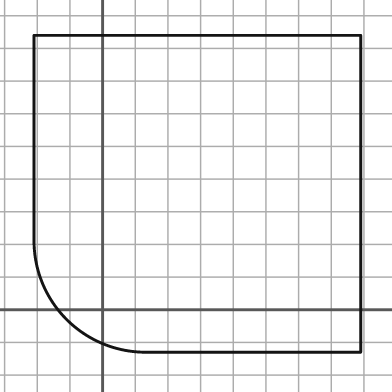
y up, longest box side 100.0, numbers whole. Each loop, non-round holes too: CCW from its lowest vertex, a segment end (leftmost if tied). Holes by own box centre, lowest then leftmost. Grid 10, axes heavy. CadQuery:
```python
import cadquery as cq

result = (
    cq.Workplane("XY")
    .moveTo(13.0, -13.0)
    .lineTo(79.0, -13.0)
    .lineTo(79.0, 84.0)
    .lineTo(-21.0, 84.0)
    .lineTo(-21.0, 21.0)
    .threePointArc((-11.0, -3.0), (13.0, -13.0))
    .close()
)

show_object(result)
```